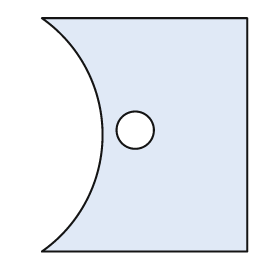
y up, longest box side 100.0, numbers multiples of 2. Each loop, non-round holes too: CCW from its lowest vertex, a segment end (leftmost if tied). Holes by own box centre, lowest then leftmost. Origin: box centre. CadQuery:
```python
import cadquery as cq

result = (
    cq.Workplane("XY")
    .moveTo(-44.0, -50.0)
    .lineTo(44.0, -50.0)
    .lineTo(44.0, 50.0)
    .lineTo(-44.0, 50.0)
    .threePointArc((-18.0, 0.0), (-44.0, -50.0))
    .close()
    .moveTo(-4.0, 2.0)
    .circle(8.0)
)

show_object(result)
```